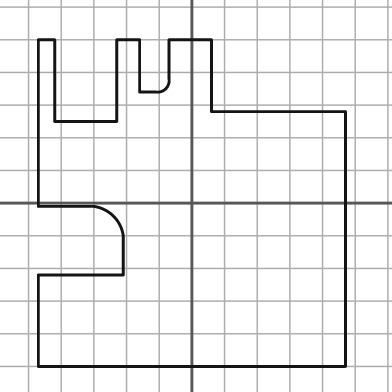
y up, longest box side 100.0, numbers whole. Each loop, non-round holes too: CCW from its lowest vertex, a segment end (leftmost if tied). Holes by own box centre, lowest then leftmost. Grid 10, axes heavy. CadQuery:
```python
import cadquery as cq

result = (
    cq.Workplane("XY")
    .moveTo(-47.0, -50.0)
    .lineTo(47.0, -50.0)
    .lineTo(47.0, 28.0)
    .lineTo(6.0, 28.0)
    .lineTo(6.0, 50.0)
    .lineTo(-7.0, 50.0)
    .lineTo(-7.0, 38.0)
    .threePointArc((-8.0, 35.0), (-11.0, 34.0))
    .lineTo(-16.0, 34.0)
    .lineTo(-16.0, 50.0)
    .lineTo(-23.0, 50.0)
    .lineTo(-23.0, 25.0)
    .lineTo(-42.0, 25.0)
    .lineTo(-42.0, 50.0)
    .lineTo(-47.0, 50.0)
    .lineTo(-47.0, -1.0)
    .lineTo(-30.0, -1.0)
    .threePointArc((-24.0, -4.0), (-21.0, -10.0))
    .lineTo(-21.0, -22.0)
    .lineTo(-47.0, -22.0)
    .close()
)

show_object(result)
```